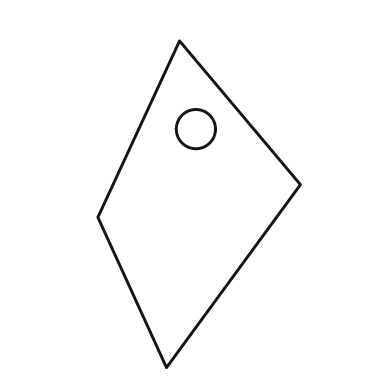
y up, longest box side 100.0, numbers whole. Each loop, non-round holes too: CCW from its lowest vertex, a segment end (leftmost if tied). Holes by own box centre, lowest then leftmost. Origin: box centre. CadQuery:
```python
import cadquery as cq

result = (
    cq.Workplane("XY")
    .moveTo(-10.0, -50.0)
    .lineTo(31.0, 6.0)
    .lineTo(-6.0, 50.0)
    .lineTo(-31.0, -4.0)
    .close()
    .moveTo(-1.0, 23.0)
    .circle(6.0)
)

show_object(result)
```